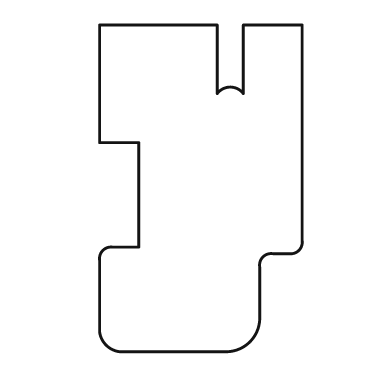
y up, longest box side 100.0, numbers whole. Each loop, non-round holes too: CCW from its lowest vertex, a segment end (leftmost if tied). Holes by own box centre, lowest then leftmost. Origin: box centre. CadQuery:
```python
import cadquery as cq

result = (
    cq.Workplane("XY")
    .moveTo(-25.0, -50.0)
    .lineTo(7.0, -50.0)
    .threePointArc((15.0, -47.0), (18.0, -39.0))
    .lineTo(18.0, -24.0)
    .threePointArc((19.0, -21.0), (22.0, -20.0))
    .lineTo(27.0, -20.0)
    .threePointArc((30.0, -19.0), (31.0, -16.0))
    .lineTo(31.0, 50.0)
    .lineTo(13.0, 50.0)
    .lineTo(13.0, 29.0)
    .threePointArc((9.0, 31.0), (5.0, 29.0))
    .lineTo(5.0, 50.0)
    .lineTo(-31.0, 50.0)
    .lineTo(-31.0, 14.0)
    .lineTo(-19.0, 14.0)
    .lineTo(-19.0, -18.0)
    .lineTo(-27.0, -18.0)
    .threePointArc((-30.0, -19.0), (-31.0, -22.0))
    .lineTo(-31.0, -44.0)
    .threePointArc((-29.0, -48.0), (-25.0, -50.0))
    .close()
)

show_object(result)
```